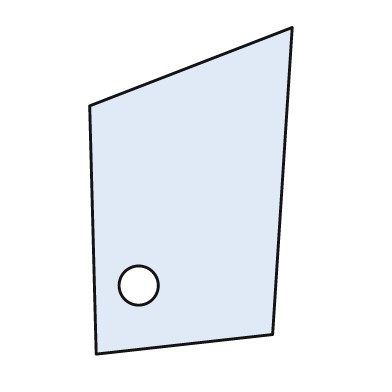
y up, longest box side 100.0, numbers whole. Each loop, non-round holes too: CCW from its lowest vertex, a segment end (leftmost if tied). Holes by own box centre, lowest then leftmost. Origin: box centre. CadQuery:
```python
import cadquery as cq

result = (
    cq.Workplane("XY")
    .moveTo(-29.0, -50.0)
    .lineTo(25.0, -44.0)
    .lineTo(31.0, 50.0)
    .lineTo(-31.0, 26.0)
    .close()
    .moveTo(-16.0, -29.0)
    .circle(6.0)
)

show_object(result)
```